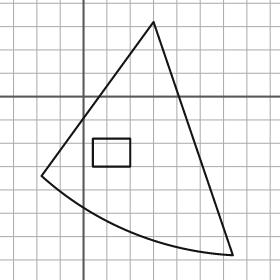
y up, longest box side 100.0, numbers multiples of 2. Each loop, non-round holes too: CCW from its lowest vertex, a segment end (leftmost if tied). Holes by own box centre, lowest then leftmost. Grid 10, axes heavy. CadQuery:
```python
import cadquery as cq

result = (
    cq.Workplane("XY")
    .moveTo(64.0, -68.0)
    .lineTo(30.0, 32.0)
    .lineTo(-18.0, -34.0)
    .threePointArc((20.0, -58.0), (64.0, -68.0))
    .close()
    .moveTo(4.0, -30.0)
    .lineTo(20.0, -30.0)
    .lineTo(20.0, -18.0)
    .lineTo(4.0, -18.0)
    .close()
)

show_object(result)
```